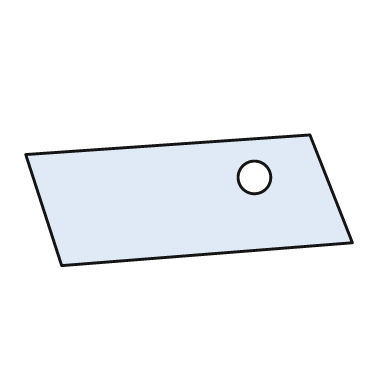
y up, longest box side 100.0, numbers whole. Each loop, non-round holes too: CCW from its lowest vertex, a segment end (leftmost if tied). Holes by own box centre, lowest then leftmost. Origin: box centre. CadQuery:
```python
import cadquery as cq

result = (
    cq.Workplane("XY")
    .moveTo(-39.0, -20.0)
    .lineTo(50.0, -13.0)
    .lineTo(37.0, 20.0)
    .lineTo(-50.0, 14.0)
    .close()
    .moveTo(20.0, 7.0)
    .circle(5.0)
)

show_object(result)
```